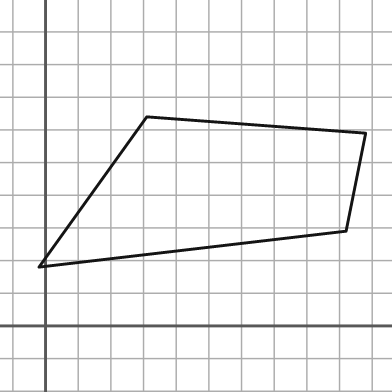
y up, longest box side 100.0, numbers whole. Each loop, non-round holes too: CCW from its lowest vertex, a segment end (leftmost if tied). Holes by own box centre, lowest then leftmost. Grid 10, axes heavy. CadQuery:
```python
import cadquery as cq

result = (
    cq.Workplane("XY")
    .moveTo(-2.0, 18.0)
    .lineTo(92.0, 29.0)
    .lineTo(98.0, 59.0)
    .lineTo(31.0, 64.0)
    .close()
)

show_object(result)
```